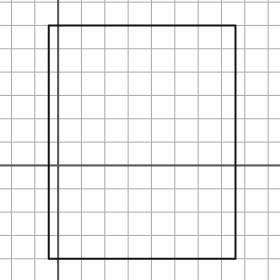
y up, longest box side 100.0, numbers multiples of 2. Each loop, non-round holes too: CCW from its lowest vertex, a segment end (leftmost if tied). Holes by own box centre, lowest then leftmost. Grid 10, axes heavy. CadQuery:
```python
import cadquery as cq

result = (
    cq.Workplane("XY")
    .moveTo(-4.0, -40.0)
    .lineTo(76.0, -40.0)
    .lineTo(76.0, 60.0)
    .lineTo(-4.0, 60.0)
    .close()
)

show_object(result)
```